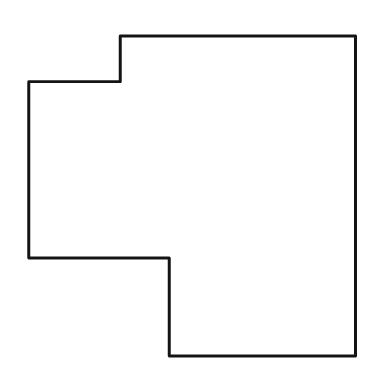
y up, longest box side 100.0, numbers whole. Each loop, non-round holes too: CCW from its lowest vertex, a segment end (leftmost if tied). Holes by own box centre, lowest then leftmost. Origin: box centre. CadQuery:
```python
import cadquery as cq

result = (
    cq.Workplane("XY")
    .moveTo(-7.0, -49.0)
    .lineTo(50.0, -49.0)
    .lineTo(50.0, 49.0)
    .lineTo(-22.0, 49.0)
    .lineTo(-22.0, 35.0)
    .lineTo(-50.0, 35.0)
    .lineTo(-50.0, -19.0)
    .lineTo(-7.0, -19.0)
    .close()
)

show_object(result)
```